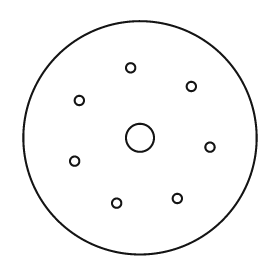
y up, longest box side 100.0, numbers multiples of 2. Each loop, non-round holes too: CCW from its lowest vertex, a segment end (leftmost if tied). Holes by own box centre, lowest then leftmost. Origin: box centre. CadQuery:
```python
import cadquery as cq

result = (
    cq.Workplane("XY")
    .moveTo(0.0, 0.0)
    .circle(50.0)
    .moveTo(-10.0, -28.0)
    .circle(2.0)
    .moveTo(16.0, -26.0)
    .circle(2.0)
    .moveTo(-28.0, -10.0)
    .circle(2.0)
    .moveTo(30.0, -4.0)
    .circle(2.0)
    .moveTo(0.0, 0.0)
    .circle(6.0)
    .moveTo(-26.0, 16.0)
    .circle(2.0)
    .moveTo(22.0, 22.0)
    .circle(2.0)
    .moveTo(-4.0, 30.0)
    .circle(2.0)
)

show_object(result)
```